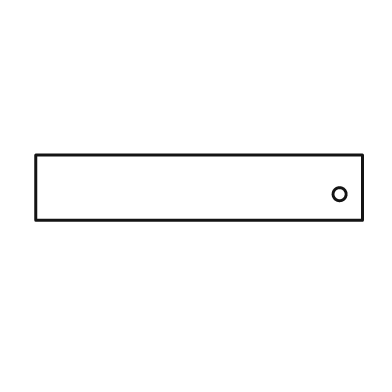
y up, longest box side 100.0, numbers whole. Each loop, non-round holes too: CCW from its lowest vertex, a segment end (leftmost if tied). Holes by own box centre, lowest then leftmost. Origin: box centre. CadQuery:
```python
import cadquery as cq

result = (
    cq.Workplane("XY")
    .moveTo(-50.0, -10.0)
    .lineTo(50.0, -10.0)
    .lineTo(50.0, 10.0)
    .lineTo(-50.0, 10.0)
    .close()
    .moveTo(43.0, -2.0)
    .circle(2.0)
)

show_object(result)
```